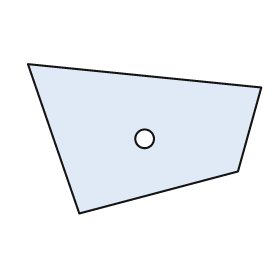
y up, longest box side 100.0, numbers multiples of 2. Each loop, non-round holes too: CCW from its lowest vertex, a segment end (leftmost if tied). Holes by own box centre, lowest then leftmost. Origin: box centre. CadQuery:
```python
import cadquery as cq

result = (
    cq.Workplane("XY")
    .moveTo(-28.0, -32.0)
    .lineTo(40.0, -14.0)
    .lineTo(50.0, 22.0)
    .lineTo(-50.0, 32.0)
    .close()
    .moveTo(0.0, 0.0)
    .circle(4.0)
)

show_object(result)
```